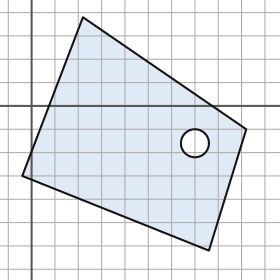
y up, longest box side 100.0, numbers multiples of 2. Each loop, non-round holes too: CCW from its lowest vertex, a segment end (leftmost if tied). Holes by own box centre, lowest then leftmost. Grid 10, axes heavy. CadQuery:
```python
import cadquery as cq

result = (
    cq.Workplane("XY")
    .moveTo(76.0, -62.0)
    .lineTo(92.0, -10.0)
    .lineTo(22.0, 38.0)
    .lineTo(-4.0, -30.0)
    .close()
    .moveTo(70.0, -16.0)
    .circle(6.0)
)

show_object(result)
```